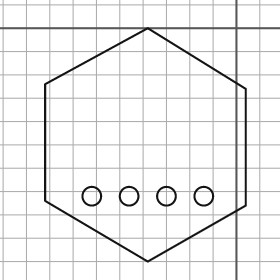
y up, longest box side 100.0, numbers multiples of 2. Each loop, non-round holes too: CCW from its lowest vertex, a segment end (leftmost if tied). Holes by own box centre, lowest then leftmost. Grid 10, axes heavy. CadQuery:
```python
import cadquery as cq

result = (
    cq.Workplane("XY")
    .moveTo(-38.0, -100.0)
    .lineTo(4.0, -76.0)
    .lineTo(4.0, -26.0)
    .lineTo(-38.0, 0.0)
    .lineTo(-82.0, -24.0)
    .lineTo(-82.0, -74.0)
    .close()
    .moveTo(-62.0, -72.0)
    .circle(4.0)
    .moveTo(-46.0, -72.0)
    .circle(4.0)
    .moveTo(-30.0, -72.0)
    .circle(4.0)
    .moveTo(-14.0, -72.0)
    .circle(4.0)
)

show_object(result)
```